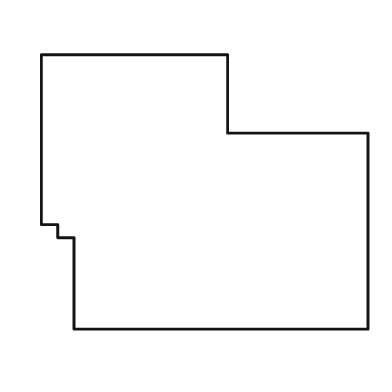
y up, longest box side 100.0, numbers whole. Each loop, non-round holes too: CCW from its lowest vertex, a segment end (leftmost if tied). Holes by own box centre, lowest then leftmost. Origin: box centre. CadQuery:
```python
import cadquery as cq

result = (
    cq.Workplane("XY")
    .moveTo(-40.0, -42.0)
    .lineTo(50.0, -42.0)
    .lineTo(50.0, 18.0)
    .lineTo(7.0, 18.0)
    .lineTo(7.0, 42.0)
    .lineTo(-50.0, 42.0)
    .lineTo(-50.0, -10.0)
    .lineTo(-45.0, -10.0)
    .lineTo(-45.0, -14.0)
    .lineTo(-40.0, -14.0)
    .close()
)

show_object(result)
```